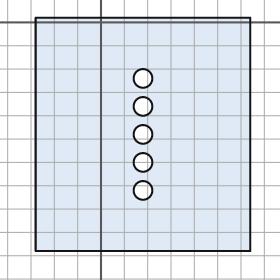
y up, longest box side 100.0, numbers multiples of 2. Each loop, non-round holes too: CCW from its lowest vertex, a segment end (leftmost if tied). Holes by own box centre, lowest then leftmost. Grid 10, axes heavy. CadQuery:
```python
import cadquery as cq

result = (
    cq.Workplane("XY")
    .moveTo(-28.0, -98.0)
    .lineTo(64.0, -98.0)
    .lineTo(64.0, 2.0)
    .lineTo(-28.0, 2.0)
    .close()
    .moveTo(18.0, -72.0)
    .circle(4.0)
    .moveTo(18.0, -60.0)
    .circle(4.0)
    .moveTo(18.0, -48.0)
    .circle(4.0)
    .moveTo(18.0, -36.0)
    .circle(4.0)
    .moveTo(18.0, -24.0)
    .circle(4.0)
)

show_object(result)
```